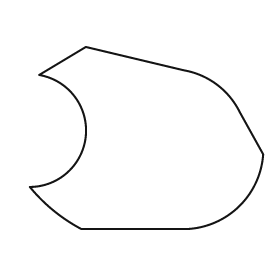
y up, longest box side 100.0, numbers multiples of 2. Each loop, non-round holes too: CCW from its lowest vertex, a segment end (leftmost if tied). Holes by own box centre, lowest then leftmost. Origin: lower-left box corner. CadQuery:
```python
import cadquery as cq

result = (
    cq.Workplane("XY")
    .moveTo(22.0, 0.0)
    .lineTo(68.0, 0.0)
    .threePointArc((90.0, 10.0), (100.0, 32.0))
    .lineTo(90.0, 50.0)
    .threePointArc((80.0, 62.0), (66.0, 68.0))
    .lineTo(24.0, 78.0)
    .lineTo(4.0, 66.0)
    .threePointArc((24.0, 40.0), (0.0, 18.0))
    .threePointArc((10.0, 8.0), (22.0, 0.0))
    .close()
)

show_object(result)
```